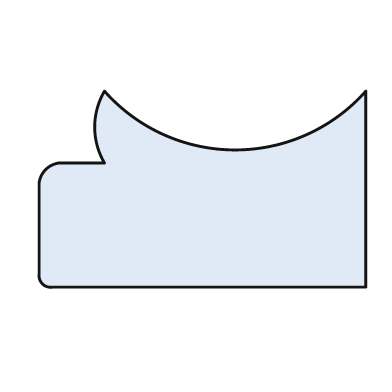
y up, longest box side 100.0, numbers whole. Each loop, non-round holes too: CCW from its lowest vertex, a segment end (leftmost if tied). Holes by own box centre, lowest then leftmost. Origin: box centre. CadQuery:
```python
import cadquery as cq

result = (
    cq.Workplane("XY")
    .moveTo(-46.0, -30.0)
    .lineTo(50.0, -30.0)
    .lineTo(50.0, 30.0)
    .threePointArc((10.0, 12.0), (-30.0, 30.0))
    .threePointArc((-33.0, 19.0), (-30.0, 8.0))
    .lineTo(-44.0, 8.0)
    .threePointArc((-48.0, 6.0), (-50.0, 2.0))
    .lineTo(-50.0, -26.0)
    .threePointArc((-49.0, -29.0), (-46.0, -30.0))
    .close()
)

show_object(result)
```